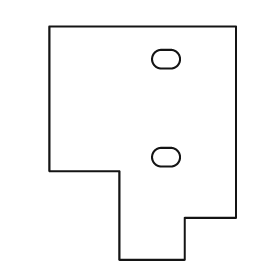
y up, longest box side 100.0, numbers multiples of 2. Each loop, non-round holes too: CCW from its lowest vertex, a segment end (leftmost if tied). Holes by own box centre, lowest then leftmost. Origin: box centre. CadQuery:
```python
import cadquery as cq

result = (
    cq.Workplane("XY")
    .moveTo(-10.0, -50.0)
    .lineTo(18.0, -50.0)
    .lineTo(18.0, -32.0)
    .lineTo(40.0, -32.0)
    .lineTo(40.0, 50.0)
    .lineTo(-40.0, 50.0)
    .lineTo(-40.0, -12.0)
    .lineTo(-10.0, -12.0)
    .close()
    .moveTo(8.0, -10.0)
    .lineTo(12.0, -10.0)
    .threePointArc((16.0, -6.0), (12.0, -2.0))
    .lineTo(8.0, -2.0)
    .threePointArc((4.0, -6.0), (8.0, -10.0))
    .close()
    .moveTo(8.0, 32.0)
    .lineTo(12.0, 32.0)
    .threePointArc((16.0, 36.0), (12.0, 40.0))
    .lineTo(8.0, 40.0)
    .threePointArc((4.0, 36.0), (8.0, 32.0))
    .close()
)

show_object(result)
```